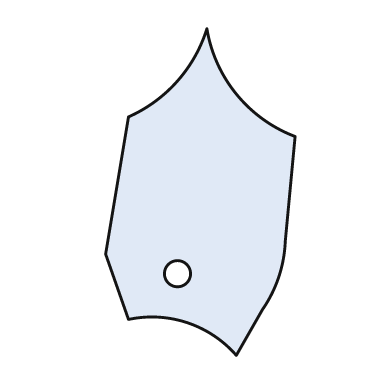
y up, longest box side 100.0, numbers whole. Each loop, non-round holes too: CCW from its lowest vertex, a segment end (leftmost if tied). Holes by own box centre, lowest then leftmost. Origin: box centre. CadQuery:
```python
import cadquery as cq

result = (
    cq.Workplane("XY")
    .moveTo(11.0, -50.0)
    .lineTo(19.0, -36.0)
    .threePointArc((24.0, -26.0), (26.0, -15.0))
    .lineTo(29.0, 17.0)
    .threePointArc((11.0, 30.0), (2.0, 50.0))
    .threePointArc((-7.0, 34.0), (-22.0, 23.0))
    .lineTo(-29.0, -19.0)
    .lineTo(-22.0, -39.0)
    .threePointArc((-4.0, -40.0), (11.0, -50.0))
    .close()
    .moveTo(-7.0, -25.0)
    .circle(4.0)
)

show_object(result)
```